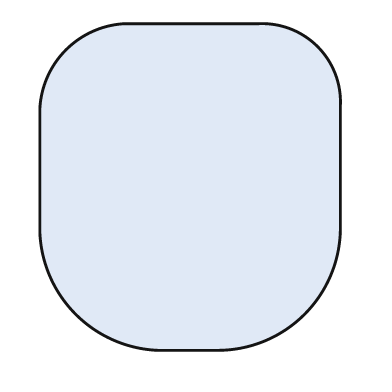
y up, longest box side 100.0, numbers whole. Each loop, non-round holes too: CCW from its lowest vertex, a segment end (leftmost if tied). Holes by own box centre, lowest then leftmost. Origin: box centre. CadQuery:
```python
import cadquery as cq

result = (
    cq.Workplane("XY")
    .moveTo(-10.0, -50.0)
    .lineTo(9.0, -50.0)
    .threePointArc((35.0, -39.0), (46.0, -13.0))
    .lineTo(46.0, 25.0)
    .threePointArc((39.0, 43.0), (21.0, 50.0))
    .lineTo(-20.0, 50.0)
    .threePointArc((-38.0, 42.0), (-46.0, 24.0))
    .lineTo(-46.0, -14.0)
    .threePointArc((-35.0, -39.0), (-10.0, -50.0))
    .close()
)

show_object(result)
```